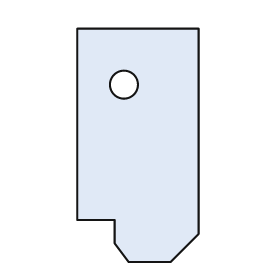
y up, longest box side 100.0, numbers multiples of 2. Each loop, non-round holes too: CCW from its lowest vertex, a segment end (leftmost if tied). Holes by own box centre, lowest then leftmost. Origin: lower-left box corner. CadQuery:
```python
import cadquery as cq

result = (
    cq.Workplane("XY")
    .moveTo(22.0, 0.0)
    .lineTo(40.0, 0.0)
    .lineTo(52.0, 12.0)
    .lineTo(52.0, 100.0)
    .lineTo(0.0, 100.0)
    .lineTo(0.0, 18.0)
    .lineTo(16.0, 18.0)
    .lineTo(16.0, 8.0)
    .close()
    .moveTo(20.0, 76.0)
    .circle(6.0)
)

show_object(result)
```